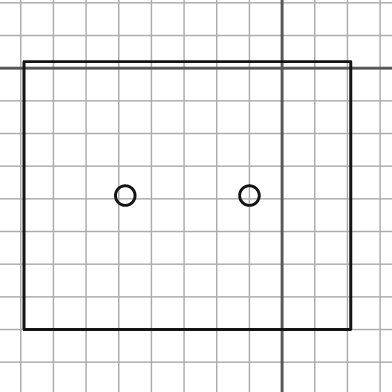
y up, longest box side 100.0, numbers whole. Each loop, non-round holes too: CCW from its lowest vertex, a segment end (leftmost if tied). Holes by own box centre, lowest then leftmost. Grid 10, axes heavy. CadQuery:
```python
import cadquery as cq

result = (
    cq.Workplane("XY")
    .moveTo(-79.0, -80.0)
    .lineTo(21.0, -80.0)
    .lineTo(21.0, 2.0)
    .lineTo(-79.0, 2.0)
    .close()
    .moveTo(-48.0, -39.0)
    .circle(3.0)
    .moveTo(-10.0, -39.0)
    .circle(3.0)
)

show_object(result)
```